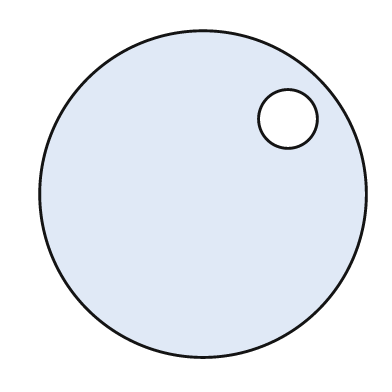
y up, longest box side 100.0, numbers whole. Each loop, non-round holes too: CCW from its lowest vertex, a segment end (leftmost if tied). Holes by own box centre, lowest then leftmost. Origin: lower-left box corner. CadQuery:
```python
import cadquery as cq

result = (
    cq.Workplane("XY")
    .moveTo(50.0, 50.0)
    .circle(50.0)
    .moveTo(76.0, 73.0)
    .circle(9.0)
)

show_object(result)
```